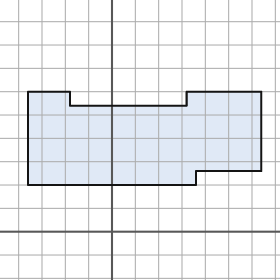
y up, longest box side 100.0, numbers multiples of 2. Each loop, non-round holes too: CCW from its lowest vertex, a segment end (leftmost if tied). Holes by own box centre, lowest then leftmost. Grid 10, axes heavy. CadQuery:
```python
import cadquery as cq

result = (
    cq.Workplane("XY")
    .moveTo(-36.0, 20.0)
    .lineTo(36.0, 20.0)
    .lineTo(36.0, 26.0)
    .lineTo(64.0, 26.0)
    .lineTo(64.0, 60.0)
    .lineTo(32.0, 60.0)
    .lineTo(32.0, 54.0)
    .lineTo(-18.0, 54.0)
    .lineTo(-18.0, 60.0)
    .lineTo(-36.0, 60.0)
    .close()
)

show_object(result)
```